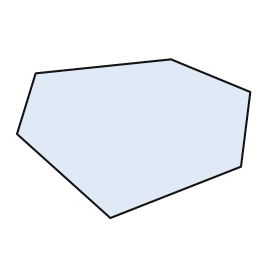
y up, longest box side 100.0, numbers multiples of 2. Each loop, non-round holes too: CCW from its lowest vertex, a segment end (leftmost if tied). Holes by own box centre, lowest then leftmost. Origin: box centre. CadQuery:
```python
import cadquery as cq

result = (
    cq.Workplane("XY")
    .moveTo(-10.0, -34.0)
    .lineTo(46.0, -12.0)
    .lineTo(50.0, 20.0)
    .lineTo(16.0, 34.0)
    .lineTo(-42.0, 28.0)
    .lineTo(-50.0, 2.0)
    .close()
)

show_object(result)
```